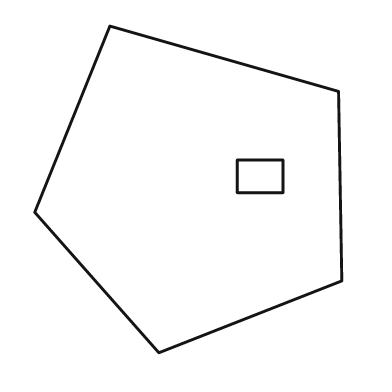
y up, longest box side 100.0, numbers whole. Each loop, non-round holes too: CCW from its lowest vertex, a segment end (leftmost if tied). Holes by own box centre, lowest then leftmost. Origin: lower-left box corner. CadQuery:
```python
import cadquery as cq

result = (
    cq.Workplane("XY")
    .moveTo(38.0, 0.0)
    .lineTo(94.0, 22.0)
    .lineTo(93.0, 80.0)
    .lineTo(23.0, 100.0)
    .lineTo(0.0, 43.0)
    .close()
    .moveTo(62.0, 49.0)
    .lineTo(76.0, 49.0)
    .lineTo(76.0, 59.0)
    .lineTo(62.0, 59.0)
    .close()
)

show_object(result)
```